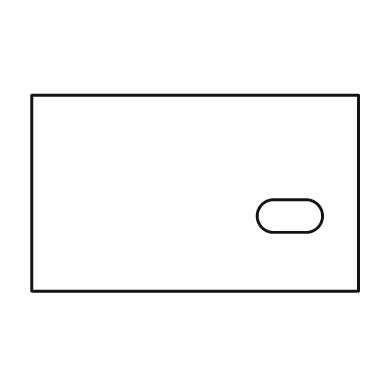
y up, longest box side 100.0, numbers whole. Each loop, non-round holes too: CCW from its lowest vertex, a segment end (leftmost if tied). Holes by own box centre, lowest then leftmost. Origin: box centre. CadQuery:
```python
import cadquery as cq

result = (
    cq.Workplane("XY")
    .moveTo(-50.0, -30.0)
    .lineTo(50.0, -30.0)
    .lineTo(50.0, 30.0)
    .lineTo(-50.0, 30.0)
    .close()
    .moveTo(24.0, -12.0)
    .lineTo(34.0, -12.0)
    .threePointArc((39.0, -7.0), (34.0, -2.0))
    .lineTo(24.0, -2.0)
    .threePointArc((19.0, -7.0), (24.0, -12.0))
    .close()
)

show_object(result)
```